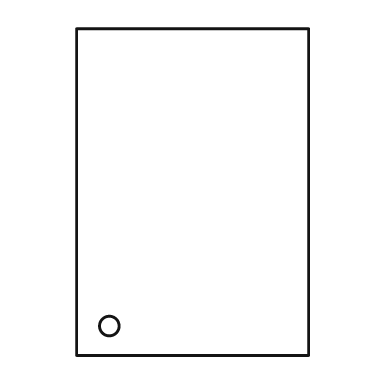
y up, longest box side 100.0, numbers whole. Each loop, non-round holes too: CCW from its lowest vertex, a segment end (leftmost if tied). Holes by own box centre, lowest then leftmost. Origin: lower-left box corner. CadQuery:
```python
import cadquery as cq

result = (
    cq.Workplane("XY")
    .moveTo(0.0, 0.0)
    .lineTo(71.0, 0.0)
    .lineTo(71.0, 100.0)
    .lineTo(0.0, 100.0)
    .close()
    .moveTo(10.0, 9.0)
    .circle(3.0)
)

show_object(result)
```